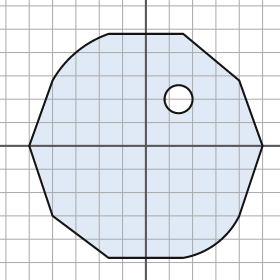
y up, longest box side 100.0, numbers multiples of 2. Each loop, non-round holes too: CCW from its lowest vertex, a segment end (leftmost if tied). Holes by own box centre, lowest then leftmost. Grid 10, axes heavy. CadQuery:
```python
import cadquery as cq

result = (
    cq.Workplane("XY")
    .moveTo(-16.0, -48.0)
    .lineTo(16.0, -48.0)
    .threePointArc((30.0, -42.0), (40.0, -30.0))
    .lineTo(50.0, 0.0)
    .lineTo(40.0, 28.0)
    .lineTo(16.0, 48.0)
    .lineTo(-16.0, 48.0)
    .threePointArc((-30.0, 40.0), (-40.0, 28.0))
    .lineTo(-50.0, 0.0)
    .lineTo(-40.0, -30.0)
    .close()
    .moveTo(14.0, 20.0)
    .circle(6.0)
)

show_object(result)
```